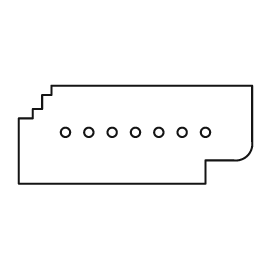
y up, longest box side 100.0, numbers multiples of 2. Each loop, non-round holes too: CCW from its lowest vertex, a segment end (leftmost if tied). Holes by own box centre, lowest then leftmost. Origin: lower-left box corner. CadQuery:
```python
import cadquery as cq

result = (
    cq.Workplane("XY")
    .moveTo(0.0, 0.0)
    .lineTo(80.0, 0.0)
    .lineTo(80.0, 10.0)
    .lineTo(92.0, 10.0)
    .threePointArc((98.0, 12.0), (100.0, 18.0))
    .lineTo(100.0, 42.0)
    .lineTo(14.0, 42.0)
    .lineTo(14.0, 38.0)
    .lineTo(10.0, 38.0)
    .lineTo(10.0, 32.0)
    .lineTo(6.0, 32.0)
    .lineTo(6.0, 28.0)
    .lineTo(0.0, 28.0)
    .close()
    .moveTo(20.0, 22.0)
    .circle(2.0)
    .moveTo(30.0, 22.0)
    .circle(2.0)
    .moveTo(40.0, 22.0)
    .circle(2.0)
    .moveTo(50.0, 22.0)
    .circle(2.0)
    .moveTo(60.0, 22.0)
    .circle(2.0)
    .moveTo(70.0, 22.0)
    .circle(2.0)
    .moveTo(80.0, 22.0)
    .circle(2.0)
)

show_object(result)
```